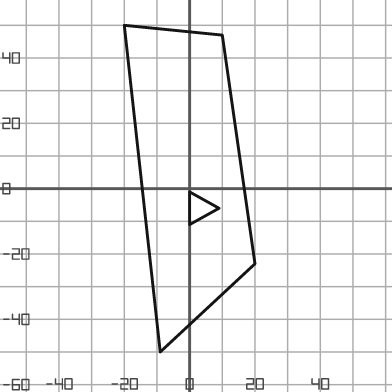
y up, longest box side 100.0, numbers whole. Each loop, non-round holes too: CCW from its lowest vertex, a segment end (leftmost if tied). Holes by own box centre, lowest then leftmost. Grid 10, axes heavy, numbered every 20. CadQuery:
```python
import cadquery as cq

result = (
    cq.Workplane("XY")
    .moveTo(-9.0, -50.0)
    .lineTo(20.0, -23.0)
    .lineTo(10.0, 47.0)
    .lineTo(-20.0, 50.0)
    .close()
    .moveTo(0.0, -11.0)
    .lineTo(9.0, -6.0)
    .lineTo(0.0, -1.0)
    .close()
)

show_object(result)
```